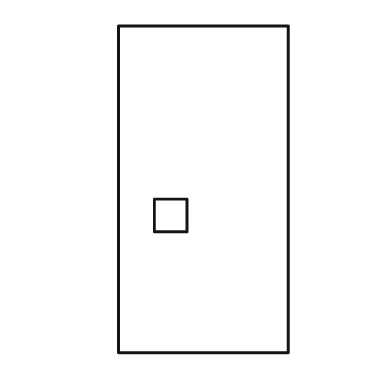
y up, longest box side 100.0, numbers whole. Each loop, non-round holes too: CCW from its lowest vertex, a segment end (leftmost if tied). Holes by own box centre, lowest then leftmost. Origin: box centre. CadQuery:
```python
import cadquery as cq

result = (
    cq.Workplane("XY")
    .moveTo(-26.0, -50.0)
    .lineTo(26.0, -50.0)
    .lineTo(26.0, 50.0)
    .lineTo(-26.0, 50.0)
    .close()
    .moveTo(-15.0, -13.0)
    .lineTo(-5.0, -13.0)
    .lineTo(-5.0, -3.0)
    .lineTo(-15.0, -3.0)
    .close()
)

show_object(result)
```